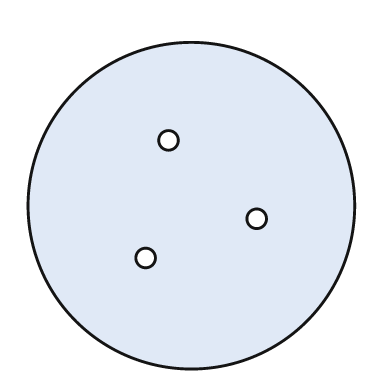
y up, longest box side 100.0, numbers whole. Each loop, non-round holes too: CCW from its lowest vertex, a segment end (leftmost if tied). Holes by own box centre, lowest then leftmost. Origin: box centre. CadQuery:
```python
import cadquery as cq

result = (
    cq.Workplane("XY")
    .moveTo(0.0, 0.0)
    .circle(50.0)
    .moveTo(-14.0, -16.0)
    .circle(3.0)
    .moveTo(20.0, -4.0)
    .circle(3.0)
    .moveTo(-7.0, 20.0)
    .circle(3.0)
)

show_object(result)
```